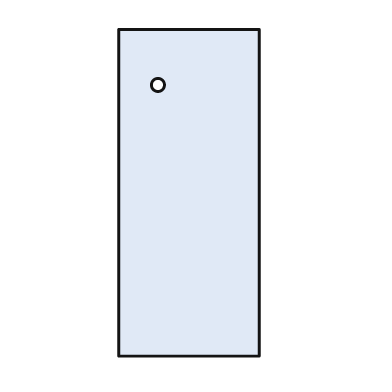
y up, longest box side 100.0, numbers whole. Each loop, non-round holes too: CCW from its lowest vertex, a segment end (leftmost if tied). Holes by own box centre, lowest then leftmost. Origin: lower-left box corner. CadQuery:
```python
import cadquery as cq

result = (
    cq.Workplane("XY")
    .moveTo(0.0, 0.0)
    .lineTo(43.0, 0.0)
    .lineTo(43.0, 100.0)
    .lineTo(0.0, 100.0)
    .close()
    .moveTo(12.0, 83.0)
    .circle(2.0)
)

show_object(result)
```